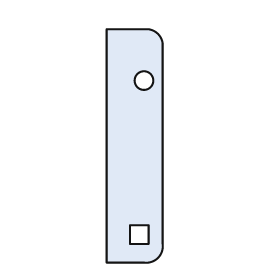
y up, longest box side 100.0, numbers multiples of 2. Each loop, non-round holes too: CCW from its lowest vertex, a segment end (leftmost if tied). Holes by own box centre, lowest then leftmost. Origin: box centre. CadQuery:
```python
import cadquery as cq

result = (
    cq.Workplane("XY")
    .moveTo(-12.0, -50.0)
    .lineTo(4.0, -50.0)
    .threePointArc((10.0, -48.0), (12.0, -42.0))
    .lineTo(12.0, 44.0)
    .threePointArc((10.0, 48.0), (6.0, 50.0))
    .lineTo(-12.0, 50.0)
    .close()
    .moveTo(-2.0, -42.0)
    .lineTo(6.0, -42.0)
    .lineTo(6.0, -34.0)
    .lineTo(-2.0, -34.0)
    .close()
    .moveTo(4.0, 28.0)
    .circle(4.0)
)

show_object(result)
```